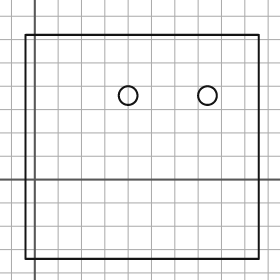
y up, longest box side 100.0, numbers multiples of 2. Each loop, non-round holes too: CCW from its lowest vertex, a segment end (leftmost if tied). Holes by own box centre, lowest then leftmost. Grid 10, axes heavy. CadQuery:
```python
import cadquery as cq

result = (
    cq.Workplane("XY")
    .moveTo(-4.0, -34.0)
    .lineTo(96.0, -34.0)
    .lineTo(96.0, 62.0)
    .lineTo(-4.0, 62.0)
    .close()
    .moveTo(40.0, 36.0)
    .circle(4.0)
    .moveTo(74.0, 36.0)
    .circle(4.0)
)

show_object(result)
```